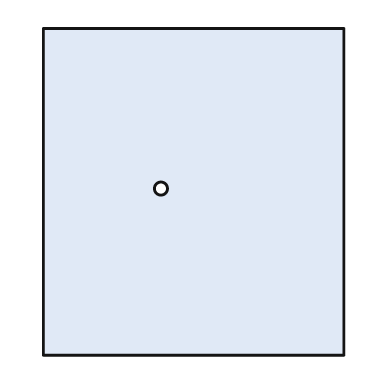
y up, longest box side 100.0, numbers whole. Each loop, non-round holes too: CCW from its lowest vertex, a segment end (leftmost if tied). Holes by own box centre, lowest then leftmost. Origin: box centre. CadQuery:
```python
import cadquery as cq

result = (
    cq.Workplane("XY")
    .moveTo(-46.0, -50.0)
    .lineTo(46.0, -50.0)
    .lineTo(46.0, 50.0)
    .lineTo(-46.0, 50.0)
    .close()
    .moveTo(-10.0, 1.0)
    .circle(2.0)
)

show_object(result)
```